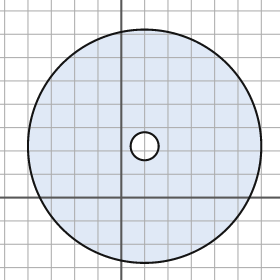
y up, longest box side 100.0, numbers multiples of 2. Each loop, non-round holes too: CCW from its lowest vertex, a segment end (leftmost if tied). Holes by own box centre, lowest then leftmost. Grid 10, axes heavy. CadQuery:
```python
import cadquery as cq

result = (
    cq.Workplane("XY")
    .moveTo(10.0, 22.0)
    .circle(50.0)
    .moveTo(10.0, 22.0)
    .circle(6.0)
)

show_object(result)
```